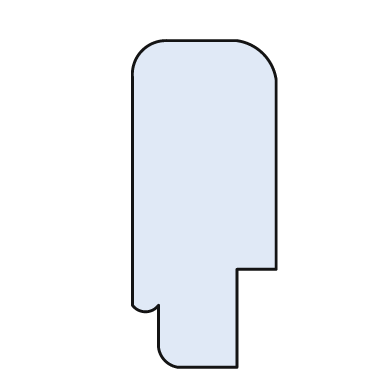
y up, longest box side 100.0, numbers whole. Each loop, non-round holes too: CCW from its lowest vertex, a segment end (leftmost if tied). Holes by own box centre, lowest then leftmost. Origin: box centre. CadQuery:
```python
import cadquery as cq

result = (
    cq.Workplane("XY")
    .moveTo(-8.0, -50.0)
    .lineTo(10.0, -50.0)
    .lineTo(10.0, -20.0)
    .lineTo(22.0, -20.0)
    .lineTo(22.0, 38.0)
    .threePointArc((18.0, 46.0), (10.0, 50.0))
    .lineTo(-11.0, 50.0)
    .threePointArc((-19.0, 47.0), (-22.0, 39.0))
    .lineTo(-22.0, -31.0)
    .threePointArc((-18.0, -33.0), (-14.0, -31.0))
    .lineTo(-14.0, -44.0)
    .threePointArc((-12.0, -48.0), (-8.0, -50.0))
    .close()
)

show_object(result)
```